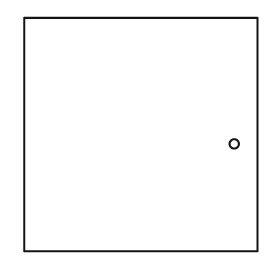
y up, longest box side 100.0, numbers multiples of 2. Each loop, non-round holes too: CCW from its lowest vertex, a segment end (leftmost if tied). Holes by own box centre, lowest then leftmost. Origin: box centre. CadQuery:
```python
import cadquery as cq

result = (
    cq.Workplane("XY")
    .moveTo(-50.0, -50.0)
    .lineTo(50.0, -50.0)
    .lineTo(50.0, 50.0)
    .lineTo(-50.0, 50.0)
    .close()
    .moveTo(40.0, -4.0)
    .circle(2.0)
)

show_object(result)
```